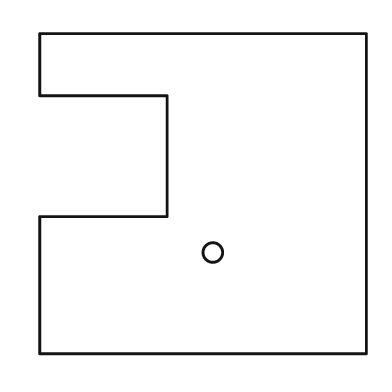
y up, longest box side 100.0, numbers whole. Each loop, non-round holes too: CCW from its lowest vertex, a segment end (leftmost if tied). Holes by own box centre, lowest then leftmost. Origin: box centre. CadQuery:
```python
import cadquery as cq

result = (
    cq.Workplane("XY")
    .moveTo(-50.0, -49.0)
    .lineTo(50.0, -49.0)
    .lineTo(50.0, 49.0)
    .lineTo(-50.0, 49.0)
    .lineTo(-50.0, 30.0)
    .lineTo(-11.0, 30.0)
    .lineTo(-11.0, -7.0)
    .lineTo(-50.0, -7.0)
    .close()
    .moveTo(3.0, -18.0)
    .circle(3.0)
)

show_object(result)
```